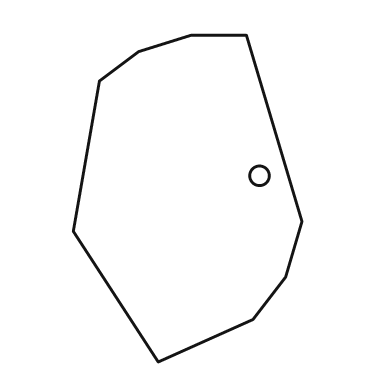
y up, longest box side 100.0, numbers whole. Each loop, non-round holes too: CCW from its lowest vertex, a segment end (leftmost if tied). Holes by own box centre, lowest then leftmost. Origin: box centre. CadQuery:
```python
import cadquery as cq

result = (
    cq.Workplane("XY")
    .moveTo(-9.0, -50.0)
    .lineTo(20.0, -37.0)
    .lineTo(30.0, -24.0)
    .lineTo(35.0, -7.0)
    .lineTo(18.0, 50.0)
    .lineTo(1.0, 50.0)
    .lineTo(-15.0, 45.0)
    .lineTo(-27.0, 36.0)
    .lineTo(-35.0, -10.0)
    .close()
    .moveTo(22.0, 7.0)
    .circle(3.0)
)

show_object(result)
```